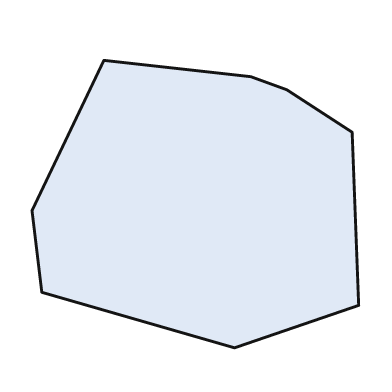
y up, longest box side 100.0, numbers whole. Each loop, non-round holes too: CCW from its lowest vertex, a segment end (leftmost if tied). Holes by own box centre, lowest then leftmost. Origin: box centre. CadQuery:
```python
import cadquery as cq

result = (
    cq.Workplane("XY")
    .moveTo(12.0, -44.0)
    .lineTo(50.0, -31.0)
    .lineTo(48.0, 22.0)
    .lineTo(28.0, 35.0)
    .lineTo(17.0, 39.0)
    .lineTo(-28.0, 44.0)
    .lineTo(-50.0, -2.0)
    .lineTo(-47.0, -27.0)
    .close()
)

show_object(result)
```